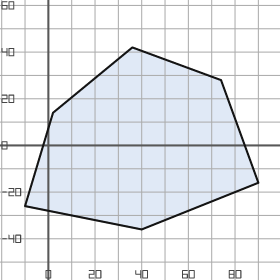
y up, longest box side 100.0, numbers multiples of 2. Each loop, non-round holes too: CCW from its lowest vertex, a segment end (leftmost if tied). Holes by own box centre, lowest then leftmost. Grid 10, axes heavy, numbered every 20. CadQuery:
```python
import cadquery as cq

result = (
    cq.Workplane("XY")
    .moveTo(40.0, -36.0)
    .lineTo(90.0, -16.0)
    .lineTo(74.0, 28.0)
    .lineTo(36.0, 42.0)
    .lineTo(2.0, 14.0)
    .lineTo(-10.0, -26.0)
    .close()
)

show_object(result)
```